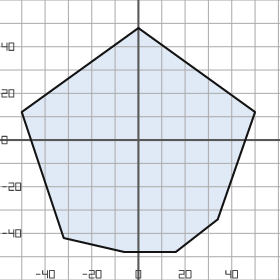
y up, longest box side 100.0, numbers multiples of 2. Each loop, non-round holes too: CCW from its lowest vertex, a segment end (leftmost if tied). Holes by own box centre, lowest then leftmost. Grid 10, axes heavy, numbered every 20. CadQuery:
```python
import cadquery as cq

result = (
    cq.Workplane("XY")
    .moveTo(-6.0, -48.0)
    .lineTo(16.0, -48.0)
    .lineTo(34.0, -34.0)
    .lineTo(50.0, 12.0)
    .lineTo(0.0, 48.0)
    .lineTo(-50.0, 12.0)
    .lineTo(-32.0, -42.0)
    .close()
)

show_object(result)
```